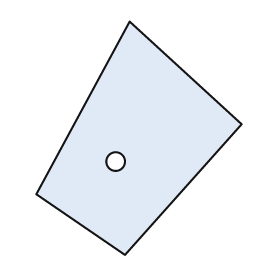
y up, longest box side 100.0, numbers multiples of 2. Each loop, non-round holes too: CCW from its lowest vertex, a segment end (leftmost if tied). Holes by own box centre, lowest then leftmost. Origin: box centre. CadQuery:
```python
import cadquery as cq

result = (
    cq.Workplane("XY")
    .moveTo(-6.0, -50.0)
    .lineTo(44.0, 6.0)
    .lineTo(-4.0, 50.0)
    .lineTo(-44.0, -24.0)
    .close()
    .moveTo(-10.0, -10.0)
    .circle(4.0)
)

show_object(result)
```